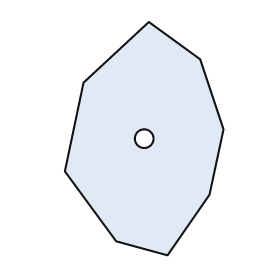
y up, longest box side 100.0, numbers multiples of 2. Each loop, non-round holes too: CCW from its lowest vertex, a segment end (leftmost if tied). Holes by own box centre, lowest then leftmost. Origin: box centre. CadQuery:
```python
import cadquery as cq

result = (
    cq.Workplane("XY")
    .moveTo(10.0, -50.0)
    .lineTo(28.0, -24.0)
    .lineTo(34.0, 4.0)
    .lineTo(24.0, 34.0)
    .lineTo(2.0, 50.0)
    .lineTo(-26.0, 24.0)
    .lineTo(-34.0, -14.0)
    .lineTo(-12.0, -44.0)
    .close()
    .moveTo(0.0, 0.0)
    .circle(4.0)
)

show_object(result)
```